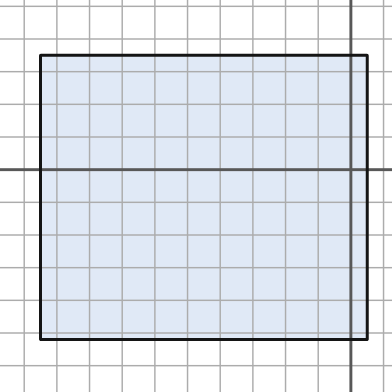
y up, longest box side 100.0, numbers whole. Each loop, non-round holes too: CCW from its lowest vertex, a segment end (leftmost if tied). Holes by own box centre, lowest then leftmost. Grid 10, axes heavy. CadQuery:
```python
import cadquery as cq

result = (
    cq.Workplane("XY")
    .moveTo(-95.0, -52.0)
    .lineTo(5.0, -52.0)
    .lineTo(5.0, 35.0)
    .lineTo(-95.0, 35.0)
    .close()
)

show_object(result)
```